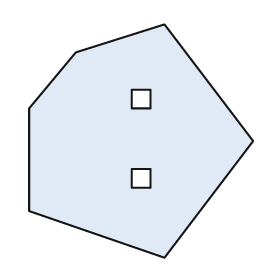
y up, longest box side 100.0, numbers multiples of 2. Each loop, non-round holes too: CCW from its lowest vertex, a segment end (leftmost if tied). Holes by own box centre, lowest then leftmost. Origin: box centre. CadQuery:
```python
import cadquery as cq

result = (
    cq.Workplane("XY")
    .moveTo(10.0, -50.0)
    .lineTo(48.0, 0.0)
    .lineTo(10.0, 50.0)
    .lineTo(-28.0, 38.0)
    .lineTo(-48.0, 14.0)
    .lineTo(-48.0, -30.0)
    .close()
    .moveTo(-4.0, -20.0)
    .lineTo(4.0, -20.0)
    .lineTo(4.0, -12.0)
    .lineTo(-4.0, -12.0)
    .close()
    .moveTo(-4.0, 14.0)
    .lineTo(4.0, 14.0)
    .lineTo(4.0, 22.0)
    .lineTo(-4.0, 22.0)
    .close()
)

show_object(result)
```